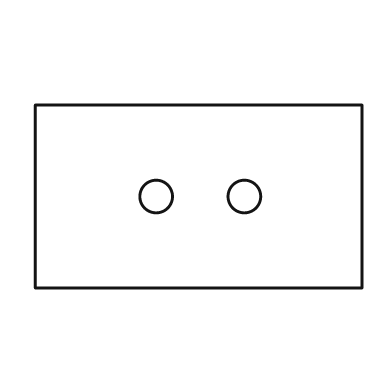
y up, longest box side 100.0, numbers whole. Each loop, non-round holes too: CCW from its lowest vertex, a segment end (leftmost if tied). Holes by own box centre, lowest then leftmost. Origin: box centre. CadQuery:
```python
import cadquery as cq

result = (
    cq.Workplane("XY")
    .moveTo(-50.0, -28.0)
    .lineTo(50.0, -28.0)
    .lineTo(50.0, 28.0)
    .lineTo(-50.0, 28.0)
    .close()
    .moveTo(-13.0, 0.0)
    .circle(5.0)
    .moveTo(14.0, 0.0)
    .circle(5.0)
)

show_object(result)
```